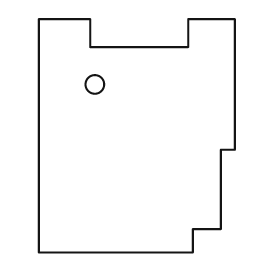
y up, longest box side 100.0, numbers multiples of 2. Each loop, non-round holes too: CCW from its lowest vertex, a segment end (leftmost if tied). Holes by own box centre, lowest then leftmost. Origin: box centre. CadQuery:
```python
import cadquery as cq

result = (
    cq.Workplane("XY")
    .moveTo(-42.0, -50.0)
    .lineTo(24.0, -50.0)
    .lineTo(24.0, -40.0)
    .lineTo(36.0, -40.0)
    .lineTo(36.0, -6.0)
    .lineTo(42.0, -6.0)
    .lineTo(42.0, 50.0)
    .lineTo(22.0, 50.0)
    .lineTo(22.0, 38.0)
    .lineTo(-20.0, 38.0)
    .lineTo(-20.0, 50.0)
    .lineTo(-42.0, 50.0)
    .close()
    .moveTo(-18.0, 22.0)
    .circle(4.0)
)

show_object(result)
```